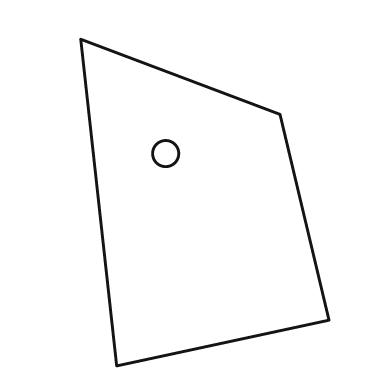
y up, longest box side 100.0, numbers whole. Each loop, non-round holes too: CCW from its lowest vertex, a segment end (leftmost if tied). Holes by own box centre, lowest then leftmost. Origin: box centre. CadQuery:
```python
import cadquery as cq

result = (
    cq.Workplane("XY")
    .moveTo(-27.0, -50.0)
    .lineTo(38.0, -36.0)
    .lineTo(23.0, 27.0)
    .lineTo(-38.0, 50.0)
    .close()
    .moveTo(-12.0, 15.0)
    .circle(4.0)
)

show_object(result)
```